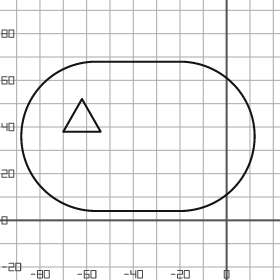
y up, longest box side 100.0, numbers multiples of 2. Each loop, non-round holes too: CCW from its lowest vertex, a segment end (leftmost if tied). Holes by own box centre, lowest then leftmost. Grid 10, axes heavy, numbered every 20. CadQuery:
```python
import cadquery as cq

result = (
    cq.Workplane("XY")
    .moveTo(-56.0, 4.0)
    .lineTo(-20.0, 4.0)
    .threePointArc((12.0, 36.0), (-20.0, 68.0))
    .lineTo(-56.0, 68.0)
    .threePointArc((-88.0, 36.0), (-56.0, 4.0))
    .close()
    .moveTo(-70.0, 38.0)
    .lineTo(-54.0, 38.0)
    .lineTo(-62.0, 52.0)
    .close()
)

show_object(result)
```